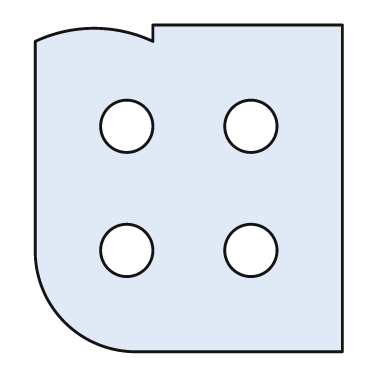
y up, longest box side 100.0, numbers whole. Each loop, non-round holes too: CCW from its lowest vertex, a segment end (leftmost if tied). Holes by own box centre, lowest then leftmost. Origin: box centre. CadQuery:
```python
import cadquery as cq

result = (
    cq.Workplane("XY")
    .moveTo(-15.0, -50.0)
    .lineTo(47.0, -50.0)
    .lineTo(47.0, 50.0)
    .lineTo(-11.0, 50.0)
    .lineTo(-11.0, 45.0)
    .threePointArc((-29.0, 49.0), (-47.0, 45.0))
    .lineTo(-47.0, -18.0)
    .threePointArc((-38.0, -41.0), (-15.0, -50.0))
    .close()
    .moveTo(-19.0, -19.0)
    .circle(8.0)
    .moveTo(19.0, -19.0)
    .circle(8.0)
    .moveTo(-19.0, 19.0)
    .circle(8.0)
    .moveTo(19.0, 19.0)
    .circle(8.0)
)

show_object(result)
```